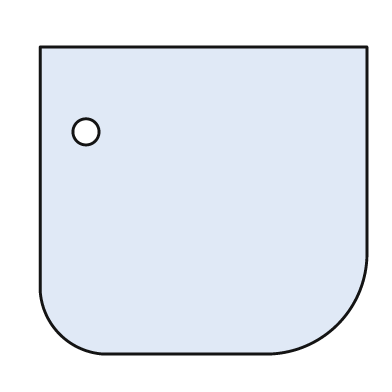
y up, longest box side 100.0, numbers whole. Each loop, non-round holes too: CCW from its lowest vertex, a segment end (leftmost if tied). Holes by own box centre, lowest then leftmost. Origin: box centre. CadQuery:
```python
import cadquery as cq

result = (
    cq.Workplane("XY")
    .moveTo(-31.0, -47.0)
    .lineTo(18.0, -47.0)
    .threePointArc((41.0, -38.0), (50.0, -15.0))
    .lineTo(50.0, 47.0)
    .lineTo(-50.0, 47.0)
    .lineTo(-50.0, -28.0)
    .threePointArc((-44.0, -41.0), (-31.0, -47.0))
    .close()
    .moveTo(-36.0, 21.0)
    .circle(4.0)
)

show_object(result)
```